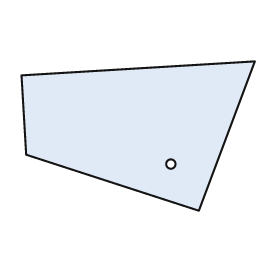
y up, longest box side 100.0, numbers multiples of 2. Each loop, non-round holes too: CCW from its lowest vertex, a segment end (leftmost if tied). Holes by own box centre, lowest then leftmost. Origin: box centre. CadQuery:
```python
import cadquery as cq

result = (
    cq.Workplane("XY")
    .moveTo(26.0, -32.0)
    .lineTo(50.0, 32.0)
    .lineTo(-50.0, 26.0)
    .lineTo(-48.0, -8.0)
    .close()
    .moveTo(14.0, -12.0)
    .circle(2.0)
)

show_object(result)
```